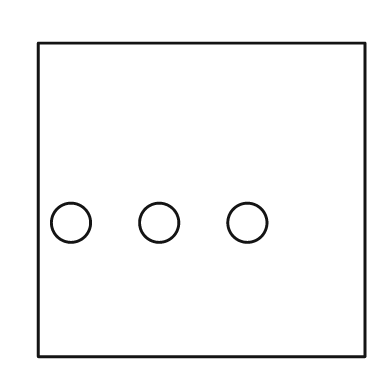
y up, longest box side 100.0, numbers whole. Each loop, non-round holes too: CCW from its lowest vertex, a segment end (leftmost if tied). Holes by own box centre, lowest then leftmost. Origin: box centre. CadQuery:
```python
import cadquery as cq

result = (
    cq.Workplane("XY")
    .moveTo(-50.0, -48.0)
    .lineTo(50.0, -48.0)
    .lineTo(50.0, 48.0)
    .lineTo(-50.0, 48.0)
    .close()
    .moveTo(-40.0, -7.0)
    .circle(6.0)
    .moveTo(-13.0, -7.0)
    .circle(6.0)
    .moveTo(14.0, -7.0)
    .circle(6.0)
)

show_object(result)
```